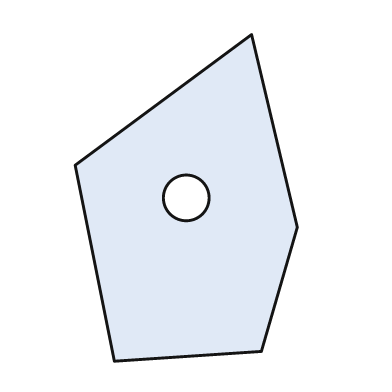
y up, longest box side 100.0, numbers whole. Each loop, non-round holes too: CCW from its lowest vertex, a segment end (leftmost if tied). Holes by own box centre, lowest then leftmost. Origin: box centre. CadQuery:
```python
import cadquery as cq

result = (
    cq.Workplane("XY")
    .moveTo(-22.0, -50.0)
    .lineTo(23.0, -47.0)
    .lineTo(34.0, -9.0)
    .lineTo(20.0, 50.0)
    .lineTo(-34.0, 10.0)
    .close()
    .moveTo(0.0, 0.0)
    .circle(7.0)
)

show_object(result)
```